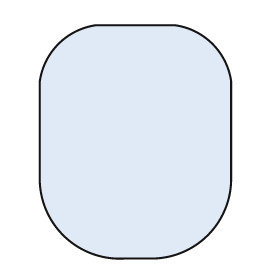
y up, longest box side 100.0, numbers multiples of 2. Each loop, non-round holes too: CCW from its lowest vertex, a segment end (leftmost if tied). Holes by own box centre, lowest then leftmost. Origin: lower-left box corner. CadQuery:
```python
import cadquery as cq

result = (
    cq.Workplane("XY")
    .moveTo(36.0, 0.0)
    .lineTo(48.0, 0.0)
    .threePointArc((72.0, 10.0), (82.0, 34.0))
    .lineTo(82.0, 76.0)
    .threePointArc((74.0, 92.0), (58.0, 100.0))
    .lineTo(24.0, 100.0)
    .threePointArc((8.0, 92.0), (0.0, 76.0))
    .lineTo(0.0, 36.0)
    .threePointArc((10.0, 10.0), (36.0, 0.0))
    .close()
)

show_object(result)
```